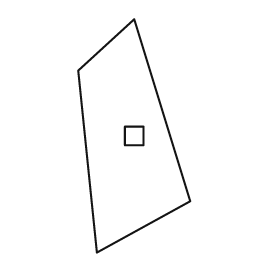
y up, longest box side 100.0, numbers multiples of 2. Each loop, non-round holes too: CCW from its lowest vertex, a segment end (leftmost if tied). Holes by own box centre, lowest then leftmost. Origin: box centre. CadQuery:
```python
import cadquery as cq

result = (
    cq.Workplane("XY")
    .moveTo(-16.0, -50.0)
    .lineTo(24.0, -28.0)
    .lineTo(0.0, 50.0)
    .lineTo(-24.0, 28.0)
    .close()
    .moveTo(-4.0, -4.0)
    .lineTo(4.0, -4.0)
    .lineTo(4.0, 4.0)
    .lineTo(-4.0, 4.0)
    .close()
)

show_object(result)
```